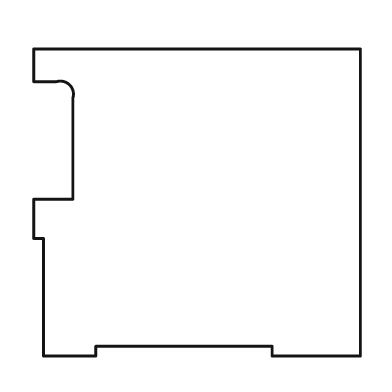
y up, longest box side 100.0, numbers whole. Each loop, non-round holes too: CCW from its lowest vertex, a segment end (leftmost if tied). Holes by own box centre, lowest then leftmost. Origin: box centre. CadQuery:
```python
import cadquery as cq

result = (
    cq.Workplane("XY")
    .moveTo(-47.0, -47.0)
    .lineTo(-31.0, -47.0)
    .lineTo(-31.0, -44.0)
    .lineTo(23.0, -44.0)
    .lineTo(23.0, -47.0)
    .lineTo(50.0, -47.0)
    .lineTo(50.0, 47.0)
    .lineTo(-50.0, 47.0)
    .lineTo(-50.0, 37.0)
    .lineTo(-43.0, 37.0)
    .threePointArc((-39.0, 36.0), (-38.0, 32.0))
    .lineTo(-38.0, 1.0)
    .lineTo(-50.0, 1.0)
    .lineTo(-50.0, -11.0)
    .lineTo(-47.0, -11.0)
    .close()
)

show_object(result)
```